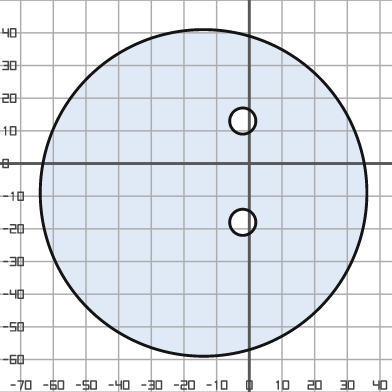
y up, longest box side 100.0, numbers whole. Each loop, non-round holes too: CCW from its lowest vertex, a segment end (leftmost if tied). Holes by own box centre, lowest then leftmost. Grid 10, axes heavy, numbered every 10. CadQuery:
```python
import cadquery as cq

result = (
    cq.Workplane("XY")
    .moveTo(-14.0, -9.0)
    .circle(50.0)
    .moveTo(-2.0, -18.0)
    .circle(4.0)
    .moveTo(-2.0, 13.0)
    .circle(4.0)
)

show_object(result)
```